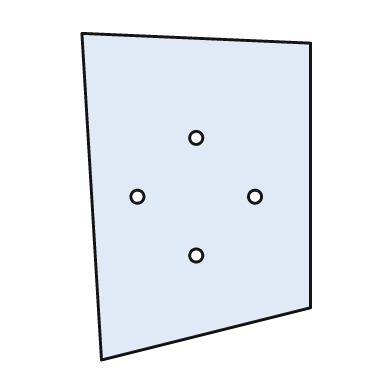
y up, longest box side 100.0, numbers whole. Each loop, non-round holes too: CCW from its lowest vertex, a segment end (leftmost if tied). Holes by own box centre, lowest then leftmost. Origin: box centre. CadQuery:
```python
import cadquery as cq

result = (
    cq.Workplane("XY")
    .moveTo(-29.0, -50.0)
    .lineTo(35.0, -34.0)
    .lineTo(35.0, 47.0)
    .lineTo(-35.0, 50.0)
    .close()
    .moveTo(0.0, -18.0)
    .circle(2.0)
    .moveTo(-18.0, 0.0)
    .circle(2.0)
    .moveTo(18.0, 0.0)
    .circle(2.0)
    .moveTo(0.0, 18.0)
    .circle(2.0)
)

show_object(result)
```